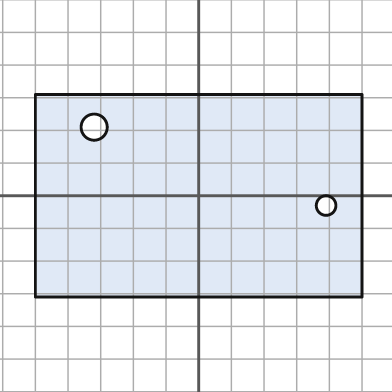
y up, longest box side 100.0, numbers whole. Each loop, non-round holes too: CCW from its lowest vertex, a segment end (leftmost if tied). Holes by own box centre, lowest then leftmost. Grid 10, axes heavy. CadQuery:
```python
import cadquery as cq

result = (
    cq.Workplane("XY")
    .moveTo(-50.0, -31.0)
    .lineTo(50.0, -31.0)
    .lineTo(50.0, 31.0)
    .lineTo(-50.0, 31.0)
    .close()
    .moveTo(39.0, -3.0)
    .circle(3.0)
    .moveTo(-32.0, 21.0)
    .circle(4.0)
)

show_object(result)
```